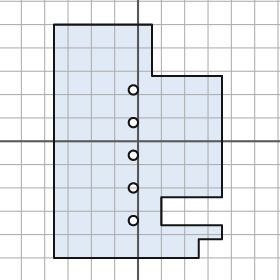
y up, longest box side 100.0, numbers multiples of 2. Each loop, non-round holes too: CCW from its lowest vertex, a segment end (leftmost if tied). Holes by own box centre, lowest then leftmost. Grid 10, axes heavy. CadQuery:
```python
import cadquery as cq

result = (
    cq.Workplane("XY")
    .moveTo(-36.0, -50.0)
    .lineTo(26.0, -50.0)
    .lineTo(26.0, -42.0)
    .lineTo(36.0, -42.0)
    .lineTo(36.0, -36.0)
    .lineTo(10.0, -36.0)
    .lineTo(10.0, -24.0)
    .lineTo(36.0, -24.0)
    .lineTo(36.0, 28.0)
    .lineTo(6.0, 28.0)
    .lineTo(6.0, 50.0)
    .lineTo(-36.0, 50.0)
    .close()
    .moveTo(-2.0, -34.0)
    .circle(2.0)
    .moveTo(-2.0, -20.0)
    .circle(2.0)
    .moveTo(-2.0, -6.0)
    .circle(2.0)
    .moveTo(-2.0, 8.0)
    .circle(2.0)
    .moveTo(-2.0, 22.0)
    .circle(2.0)
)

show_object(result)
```